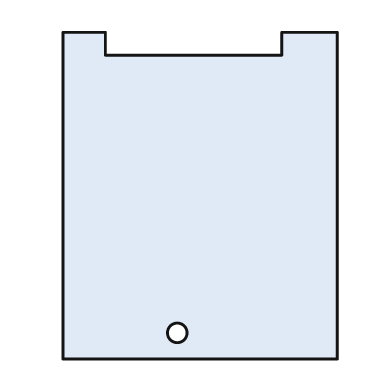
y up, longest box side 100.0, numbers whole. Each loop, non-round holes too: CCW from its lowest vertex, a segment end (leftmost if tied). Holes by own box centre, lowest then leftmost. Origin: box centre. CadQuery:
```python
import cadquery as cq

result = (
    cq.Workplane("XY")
    .moveTo(-42.0, -50.0)
    .lineTo(42.0, -50.0)
    .lineTo(42.0, 50.0)
    .lineTo(25.0, 50.0)
    .lineTo(25.0, 43.0)
    .lineTo(-29.0, 43.0)
    .lineTo(-29.0, 50.0)
    .lineTo(-42.0, 50.0)
    .close()
    .moveTo(-7.0, -42.0)
    .circle(3.0)
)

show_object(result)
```